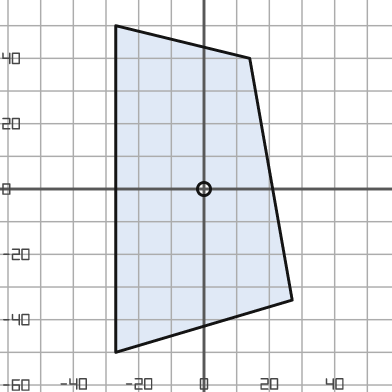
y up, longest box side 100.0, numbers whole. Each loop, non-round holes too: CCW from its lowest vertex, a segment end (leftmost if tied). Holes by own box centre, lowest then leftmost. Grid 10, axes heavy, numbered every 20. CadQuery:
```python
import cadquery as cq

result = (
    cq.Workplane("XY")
    .moveTo(-27.0, -50.0)
    .lineTo(27.0, -34.0)
    .lineTo(14.0, 40.0)
    .lineTo(-27.0, 50.0)
    .close()
    .moveTo(0.0, 0.0)
    .circle(2.0)
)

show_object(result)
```